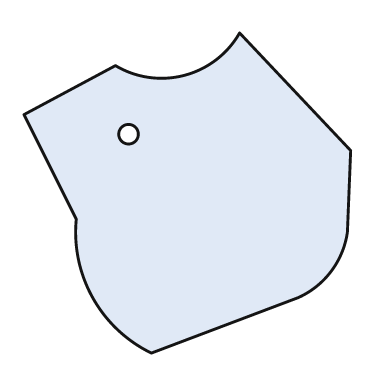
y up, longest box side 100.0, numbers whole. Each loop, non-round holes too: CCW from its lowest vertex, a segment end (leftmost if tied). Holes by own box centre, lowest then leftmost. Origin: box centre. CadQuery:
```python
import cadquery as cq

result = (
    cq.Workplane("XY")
    .moveTo(-11.0, -49.0)
    .lineTo(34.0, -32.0)
    .threePointArc((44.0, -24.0), (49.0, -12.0))
    .lineTo(50.0, 13.0)
    .lineTo(16.0, 49.0)
    .threePointArc((-1.0, 36.0), (-22.0, 39.0))
    .lineTo(-50.0, 24.0)
    .lineTo(-34.0, -8.0)
    .threePointArc((-29.0, -32.0), (-11.0, -49.0))
    .close()
    .moveTo(-18.0, 18.0)
    .circle(3.0)
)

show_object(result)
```